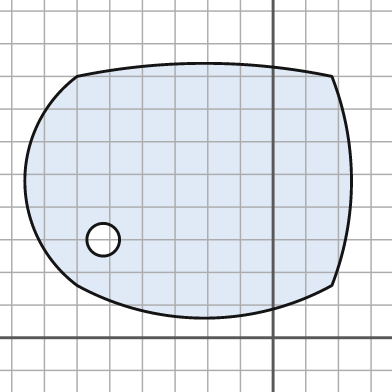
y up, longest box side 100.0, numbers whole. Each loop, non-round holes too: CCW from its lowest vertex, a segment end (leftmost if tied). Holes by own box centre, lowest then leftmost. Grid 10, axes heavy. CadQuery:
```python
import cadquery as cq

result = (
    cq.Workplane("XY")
    .moveTo(-60.0, 16.0)
    .threePointArc((-21.0, 6.0), (18.0, 16.0))
    .threePointArc((24.0, 48.0), (18.0, 80.0))
    .threePointArc((-21.0, 84.0), (-60.0, 80.0))
    .threePointArc((-76.0, 48.0), (-60.0, 16.0))
    .close()
    .moveTo(-52.0, 30.0)
    .circle(5.0)
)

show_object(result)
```